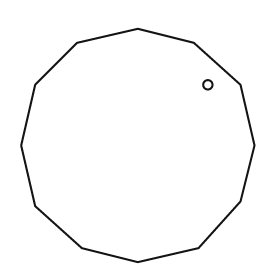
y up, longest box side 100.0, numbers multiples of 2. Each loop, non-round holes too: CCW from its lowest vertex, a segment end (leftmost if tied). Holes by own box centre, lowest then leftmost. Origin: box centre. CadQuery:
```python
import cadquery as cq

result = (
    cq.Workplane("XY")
    .moveTo(0.0, -50.0)
    .lineTo(26.0, -44.0)
    .lineTo(44.0, -24.0)
    .lineTo(50.0, 0.0)
    .lineTo(44.0, 26.0)
    .lineTo(24.0, 44.0)
    .lineTo(0.0, 50.0)
    .lineTo(-26.0, 44.0)
    .lineTo(-44.0, 26.0)
    .lineTo(-50.0, 0.0)
    .lineTo(-44.0, -26.0)
    .lineTo(-24.0, -44.0)
    .close()
    .moveTo(30.0, 26.0)
    .circle(2.0)
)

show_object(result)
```